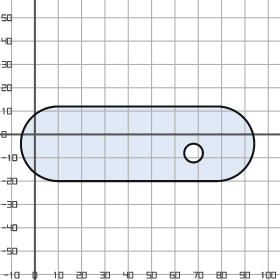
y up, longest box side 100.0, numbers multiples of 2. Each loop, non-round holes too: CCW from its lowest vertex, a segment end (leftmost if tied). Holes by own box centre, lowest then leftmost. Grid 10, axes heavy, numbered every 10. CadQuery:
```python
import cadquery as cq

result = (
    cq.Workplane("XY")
    .moveTo(10.0, -20.0)
    .lineTo(78.0, -20.0)
    .threePointArc((94.0, -4.0), (78.0, 12.0))
    .lineTo(10.0, 12.0)
    .threePointArc((-6.0, -4.0), (10.0, -20.0))
    .close()
    .moveTo(68.0, -8.0)
    .circle(4.0)
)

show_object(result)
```